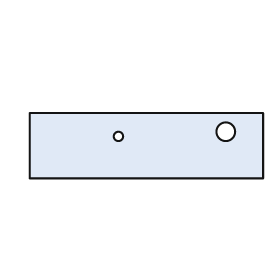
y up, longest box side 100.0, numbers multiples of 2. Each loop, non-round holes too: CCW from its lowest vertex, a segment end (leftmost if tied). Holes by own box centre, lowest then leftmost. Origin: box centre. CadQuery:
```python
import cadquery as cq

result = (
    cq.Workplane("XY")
    .moveTo(-50.0, -14.0)
    .lineTo(50.0, -14.0)
    .lineTo(50.0, 14.0)
    .lineTo(-50.0, 14.0)
    .close()
    .moveTo(-12.0, 4.0)
    .circle(2.0)
    .moveTo(34.0, 6.0)
    .circle(4.0)
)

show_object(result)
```